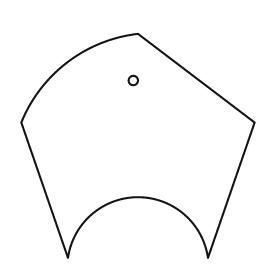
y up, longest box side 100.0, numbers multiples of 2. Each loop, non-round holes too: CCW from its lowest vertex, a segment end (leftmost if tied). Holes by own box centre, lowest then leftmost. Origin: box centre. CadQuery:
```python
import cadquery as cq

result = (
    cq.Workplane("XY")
    .moveTo(-30.0, -48.0)
    .threePointArc((0.0, -22.0), (30.0, -48.0))
    .lineTo(50.0, 10.0)
    .lineTo(0.0, 48.0)
    .threePointArc((-30.0, 36.0), (-50.0, 10.0))
    .close()
    .moveTo(-2.0, 28.0)
    .circle(2.0)
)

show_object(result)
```